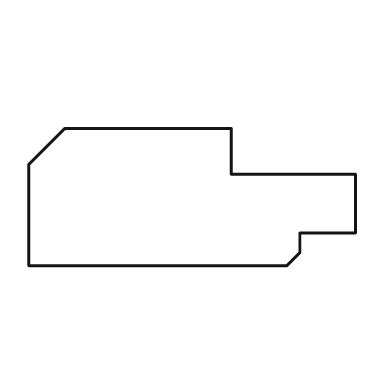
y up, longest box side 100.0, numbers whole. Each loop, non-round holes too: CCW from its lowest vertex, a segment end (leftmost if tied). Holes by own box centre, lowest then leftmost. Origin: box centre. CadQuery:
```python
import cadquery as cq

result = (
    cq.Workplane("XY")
    .moveTo(-50.0, -21.0)
    .lineTo(29.0, -21.0)
    .lineTo(33.0, -17.0)
    .lineTo(33.0, -11.0)
    .lineTo(50.0, -11.0)
    .lineTo(50.0, 7.0)
    .lineTo(12.0, 7.0)
    .lineTo(12.0, 21.0)
    .lineTo(-39.0, 21.0)
    .lineTo(-50.0, 10.0)
    .close()
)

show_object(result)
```